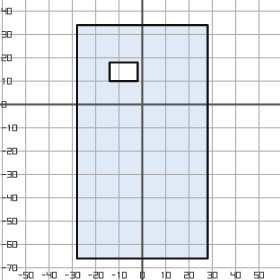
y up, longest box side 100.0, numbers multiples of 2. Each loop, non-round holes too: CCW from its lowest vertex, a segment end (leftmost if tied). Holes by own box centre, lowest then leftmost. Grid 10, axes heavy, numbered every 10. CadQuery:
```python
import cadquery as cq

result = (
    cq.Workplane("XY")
    .moveTo(-28.0, -66.0)
    .lineTo(28.0, -66.0)
    .lineTo(28.0, 34.0)
    .lineTo(-28.0, 34.0)
    .close()
    .moveTo(-14.0, 10.0)
    .lineTo(-2.0, 10.0)
    .lineTo(-2.0, 18.0)
    .lineTo(-14.0, 18.0)
    .close()
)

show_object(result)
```